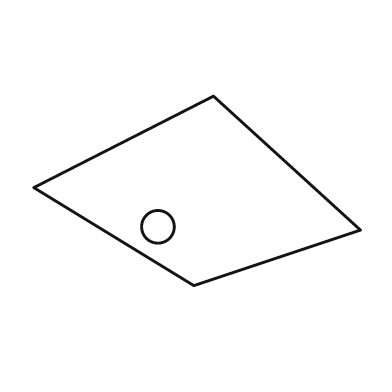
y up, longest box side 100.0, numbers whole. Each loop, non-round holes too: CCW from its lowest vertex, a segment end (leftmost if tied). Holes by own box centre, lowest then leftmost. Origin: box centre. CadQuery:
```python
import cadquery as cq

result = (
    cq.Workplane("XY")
    .moveTo(-1.0, -29.0)
    .lineTo(50.0, -12.0)
    .lineTo(5.0, 29.0)
    .lineTo(-50.0, 1.0)
    .close()
    .moveTo(-12.0, -11.0)
    .circle(5.0)
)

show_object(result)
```